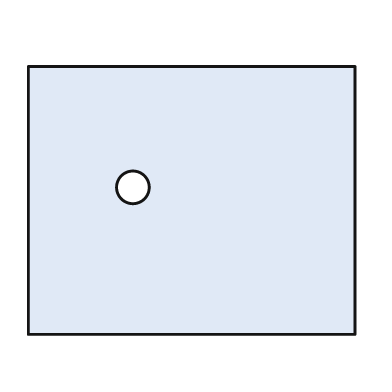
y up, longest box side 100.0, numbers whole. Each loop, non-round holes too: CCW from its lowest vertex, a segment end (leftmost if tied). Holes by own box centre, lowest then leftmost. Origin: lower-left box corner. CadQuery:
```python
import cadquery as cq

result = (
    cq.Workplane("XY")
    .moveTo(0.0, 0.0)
    .lineTo(100.0, 0.0)
    .lineTo(100.0, 82.0)
    .lineTo(0.0, 82.0)
    .close()
    .moveTo(32.0, 45.0)
    .circle(5.0)
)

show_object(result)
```